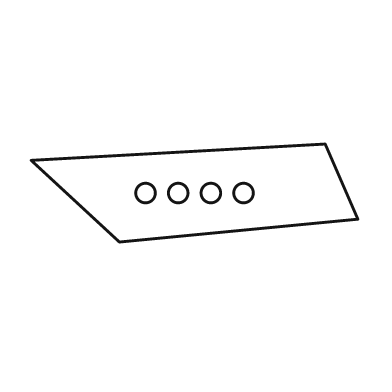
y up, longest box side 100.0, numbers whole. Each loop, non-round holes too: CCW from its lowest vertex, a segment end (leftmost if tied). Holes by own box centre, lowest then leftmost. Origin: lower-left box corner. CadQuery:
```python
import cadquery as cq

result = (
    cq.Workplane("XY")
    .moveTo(27.0, 0.0)
    .lineTo(100.0, 7.0)
    .lineTo(90.0, 30.0)
    .lineTo(0.0, 25.0)
    .close()
    .moveTo(35.0, 15.0)
    .circle(3.0)
    .moveTo(45.0, 15.0)
    .circle(3.0)
    .moveTo(55.0, 15.0)
    .circle(3.0)
    .moveTo(65.0, 15.0)
    .circle(3.0)
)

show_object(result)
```